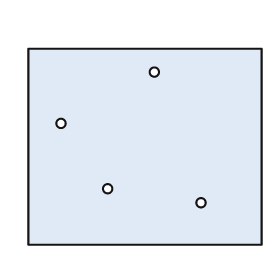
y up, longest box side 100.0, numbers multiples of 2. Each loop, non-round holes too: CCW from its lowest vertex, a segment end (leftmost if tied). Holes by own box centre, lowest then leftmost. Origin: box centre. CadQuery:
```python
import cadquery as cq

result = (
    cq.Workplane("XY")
    .moveTo(-50.0, -42.0)
    .lineTo(50.0, -42.0)
    .lineTo(50.0, 42.0)
    .lineTo(-50.0, 42.0)
    .close()
    .moveTo(24.0, -24.0)
    .circle(2.0)
    .moveTo(-16.0, -18.0)
    .circle(2.0)
    .moveTo(-36.0, 10.0)
    .circle(2.0)
    .moveTo(4.0, 32.0)
    .circle(2.0)
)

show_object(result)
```